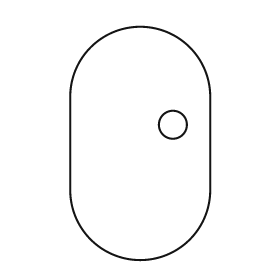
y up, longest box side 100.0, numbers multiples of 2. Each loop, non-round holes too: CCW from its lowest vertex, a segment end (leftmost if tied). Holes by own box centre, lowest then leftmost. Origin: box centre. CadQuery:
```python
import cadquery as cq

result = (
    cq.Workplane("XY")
    .moveTo(-30.0, -20.0)
    .threePointArc((0.0, -50.0), (30.0, -20.0))
    .lineTo(30.0, 20.0)
    .threePointArc((0.0, 50.0), (-30.0, 20.0))
    .close()
    .moveTo(14.0, 8.0)
    .circle(6.0)
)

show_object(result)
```